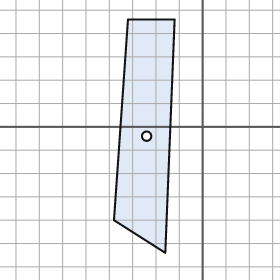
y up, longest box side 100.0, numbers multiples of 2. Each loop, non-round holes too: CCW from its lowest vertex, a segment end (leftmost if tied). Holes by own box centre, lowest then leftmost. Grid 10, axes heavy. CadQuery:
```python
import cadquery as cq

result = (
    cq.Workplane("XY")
    .moveTo(-16.0, -54.0)
    .lineTo(-12.0, 46.0)
    .lineTo(-32.0, 46.0)
    .lineTo(-38.0, -40.0)
    .close()
    .moveTo(-24.0, -4.0)
    .circle(2.0)
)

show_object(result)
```